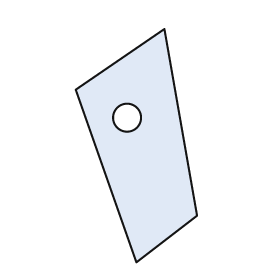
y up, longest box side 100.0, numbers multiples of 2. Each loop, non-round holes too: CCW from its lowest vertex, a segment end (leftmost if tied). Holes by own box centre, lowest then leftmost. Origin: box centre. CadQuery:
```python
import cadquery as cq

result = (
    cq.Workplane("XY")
    .moveTo(0.0, -50.0)
    .lineTo(26.0, -30.0)
    .lineTo(12.0, 50.0)
    .lineTo(-26.0, 24.0)
    .close()
    .moveTo(-4.0, 12.0)
    .circle(6.0)
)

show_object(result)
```